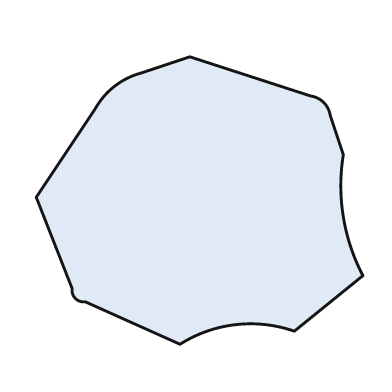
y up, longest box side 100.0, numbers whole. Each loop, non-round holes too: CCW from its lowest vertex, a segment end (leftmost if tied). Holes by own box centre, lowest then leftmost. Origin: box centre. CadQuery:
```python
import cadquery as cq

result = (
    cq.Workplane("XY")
    .moveTo(-6.0, -44.0)
    .threePointArc((11.0, -38.0), (29.0, -40.0))
    .lineTo(50.0, -23.0)
    .threePointArc((44.0, -5.0), (44.0, 14.0))
    .lineTo(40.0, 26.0)
    .threePointArc((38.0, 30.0), (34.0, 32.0))
    .lineTo(-3.0, 44.0)
    .lineTo(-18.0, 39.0)
    .threePointArc((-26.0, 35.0), (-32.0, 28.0))
    .lineTo(-50.0, 1.0)
    .lineTo(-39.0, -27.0)
    .threePointArc((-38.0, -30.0), (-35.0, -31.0))
    .close()
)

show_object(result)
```